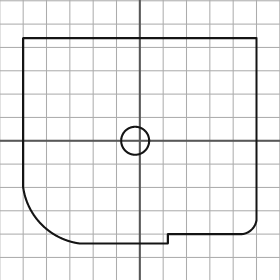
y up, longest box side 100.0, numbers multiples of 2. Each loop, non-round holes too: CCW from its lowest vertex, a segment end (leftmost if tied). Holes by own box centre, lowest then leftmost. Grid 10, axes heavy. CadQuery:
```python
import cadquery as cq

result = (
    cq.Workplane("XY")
    .moveTo(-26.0, -44.0)
    .lineTo(12.0, -44.0)
    .lineTo(12.0, -40.0)
    .lineTo(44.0, -40.0)
    .threePointArc((48.0, -38.0), (50.0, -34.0))
    .lineTo(50.0, 44.0)
    .lineTo(-50.0, 44.0)
    .lineTo(-50.0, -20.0)
    .threePointArc((-42.0, -36.0), (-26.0, -44.0))
    .close()
    .moveTo(-2.0, 0.0)
    .circle(6.0)
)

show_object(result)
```